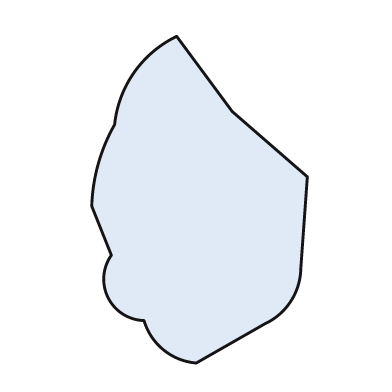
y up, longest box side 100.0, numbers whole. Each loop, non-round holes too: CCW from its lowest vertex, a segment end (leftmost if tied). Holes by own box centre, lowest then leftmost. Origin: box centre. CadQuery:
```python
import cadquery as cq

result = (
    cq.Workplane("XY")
    .moveTo(-1.0, -50.0)
    .lineTo(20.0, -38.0)
    .threePointArc((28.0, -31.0), (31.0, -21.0))
    .lineTo(33.0, 7.0)
    .lineTo(10.0, 27.0)
    .lineTo(-7.0, 50.0)
    .threePointArc((-20.0, 39.0), (-26.0, 23.0))
    .threePointArc((-31.0, 11.0), (-33.0, -2.0))
    .lineTo(-27.0, -17.0)
    .threePointArc((-28.0, -30.0), (-17.0, -37.0))
    .threePointArc((-11.0, -46.0), (-1.0, -50.0))
    .close()
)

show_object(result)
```